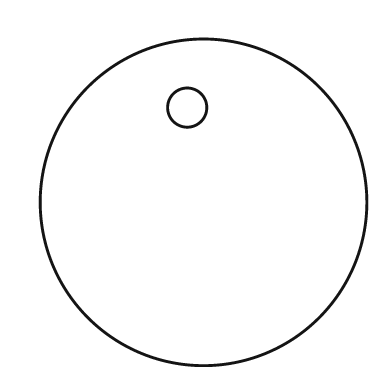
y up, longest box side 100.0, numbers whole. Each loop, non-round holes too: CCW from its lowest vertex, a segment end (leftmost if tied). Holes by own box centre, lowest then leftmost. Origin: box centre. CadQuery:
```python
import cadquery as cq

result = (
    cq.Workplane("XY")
    .moveTo(0.0, 0.0)
    .circle(50.0)
    .moveTo(-5.0, 29.0)
    .circle(6.0)
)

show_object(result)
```